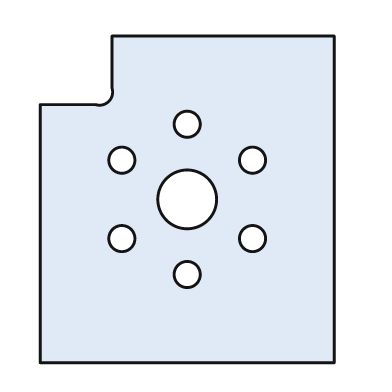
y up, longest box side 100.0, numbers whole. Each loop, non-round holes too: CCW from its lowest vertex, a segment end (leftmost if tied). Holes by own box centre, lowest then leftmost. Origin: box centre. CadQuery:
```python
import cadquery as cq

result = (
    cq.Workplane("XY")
    .moveTo(-45.0, -50.0)
    .lineTo(45.0, -50.0)
    .lineTo(45.0, 50.0)
    .lineTo(-23.0, 50.0)
    .lineTo(-23.0, 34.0)
    .threePointArc((-24.0, 30.0), (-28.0, 29.0))
    .lineTo(-45.0, 29.0)
    .close()
    .moveTo(0.0, -23.0)
    .circle(4.0)
    .moveTo(-20.0, -12.0)
    .circle(4.0)
    .moveTo(20.0, -12.0)
    .circle(4.0)
    .moveTo(0.0, 0.0)
    .circle(9.0)
    .moveTo(-20.0, 12.0)
    .circle(4.0)
    .moveTo(20.0, 12.0)
    .circle(4.0)
    .moveTo(0.0, 23.0)
    .circle(4.0)
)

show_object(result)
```